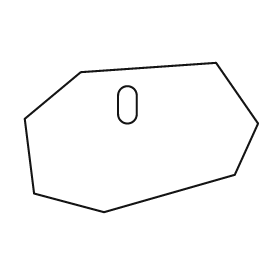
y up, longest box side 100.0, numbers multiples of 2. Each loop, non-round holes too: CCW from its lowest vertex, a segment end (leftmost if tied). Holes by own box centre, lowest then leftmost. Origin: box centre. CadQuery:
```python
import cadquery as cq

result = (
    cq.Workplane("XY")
    .moveTo(-16.0, -32.0)
    .lineTo(40.0, -16.0)
    .lineTo(50.0, 6.0)
    .lineTo(32.0, 32.0)
    .lineTo(-26.0, 28.0)
    .lineTo(-50.0, 8.0)
    .lineTo(-46.0, -24.0)
    .close()
    .moveTo(-10.0, 10.0)
    .threePointArc((-6.0, 6.0), (-2.0, 10.0))
    .lineTo(-2.0, 18.0)
    .threePointArc((-6.0, 22.0), (-10.0, 18.0))
    .close()
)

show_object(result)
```